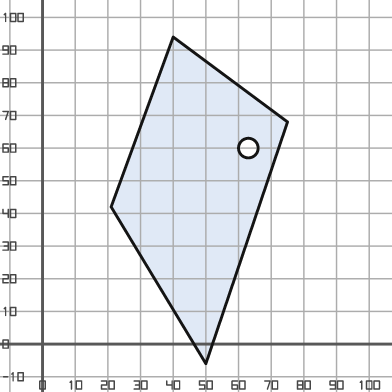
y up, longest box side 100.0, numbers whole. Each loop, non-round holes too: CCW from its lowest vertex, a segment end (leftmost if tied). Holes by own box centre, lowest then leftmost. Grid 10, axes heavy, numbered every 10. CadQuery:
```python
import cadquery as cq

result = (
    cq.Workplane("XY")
    .moveTo(50.0, -6.0)
    .lineTo(75.0, 68.0)
    .lineTo(40.0, 94.0)
    .lineTo(21.0, 42.0)
    .close()
    .moveTo(63.0, 60.0)
    .circle(3.0)
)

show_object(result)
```